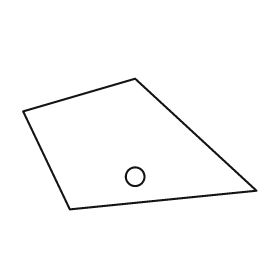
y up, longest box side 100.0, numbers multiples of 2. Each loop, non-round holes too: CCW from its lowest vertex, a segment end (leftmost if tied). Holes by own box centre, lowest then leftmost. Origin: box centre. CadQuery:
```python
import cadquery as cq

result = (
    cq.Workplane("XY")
    .moveTo(-30.0, -28.0)
    .lineTo(50.0, -20.0)
    .lineTo(-2.0, 28.0)
    .lineTo(-50.0, 14.0)
    .close()
    .moveTo(-2.0, -14.0)
    .circle(4.0)
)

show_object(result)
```